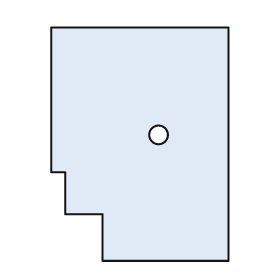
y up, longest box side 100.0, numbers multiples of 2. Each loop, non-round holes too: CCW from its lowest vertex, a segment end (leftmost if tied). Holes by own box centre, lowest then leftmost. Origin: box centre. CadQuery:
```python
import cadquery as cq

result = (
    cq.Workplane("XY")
    .moveTo(-16.0, -50.0)
    .lineTo(38.0, -50.0)
    .lineTo(38.0, 50.0)
    .lineTo(-38.0, 50.0)
    .lineTo(-38.0, -12.0)
    .lineTo(-32.0, -12.0)
    .lineTo(-32.0, -30.0)
    .lineTo(-16.0, -30.0)
    .close()
    .moveTo(8.0, 4.0)
    .circle(4.0)
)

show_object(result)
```